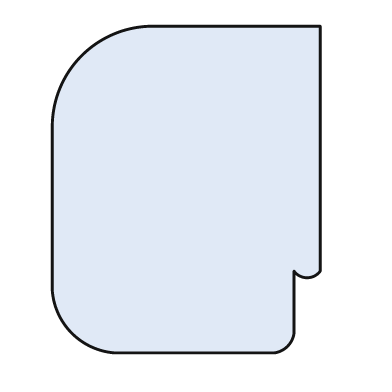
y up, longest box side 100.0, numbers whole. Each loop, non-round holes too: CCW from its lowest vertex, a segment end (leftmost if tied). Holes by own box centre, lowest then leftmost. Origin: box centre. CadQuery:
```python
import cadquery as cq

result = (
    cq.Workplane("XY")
    .moveTo(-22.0, -50.0)
    .lineTo(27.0, -50.0)
    .threePointArc((31.0, -48.0), (33.0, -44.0))
    .lineTo(33.0, -25.0)
    .threePointArc((37.0, -27.0), (41.0, -25.0))
    .lineTo(41.0, 50.0)
    .lineTo(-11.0, 50.0)
    .threePointArc((-32.0, 41.0), (-41.0, 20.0))
    .lineTo(-41.0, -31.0)
    .threePointArc((-35.0, -44.0), (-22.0, -50.0))
    .close()
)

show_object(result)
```